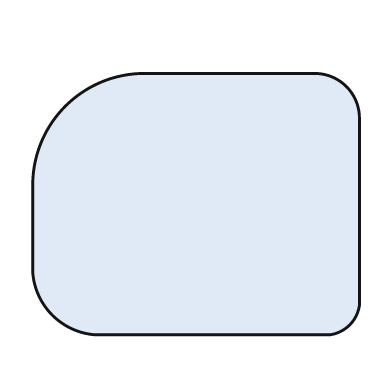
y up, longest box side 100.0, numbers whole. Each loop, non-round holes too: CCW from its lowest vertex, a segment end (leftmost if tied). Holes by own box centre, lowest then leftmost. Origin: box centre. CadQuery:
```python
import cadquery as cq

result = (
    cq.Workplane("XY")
    .moveTo(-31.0, -40.0)
    .lineTo(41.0, -40.0)
    .threePointArc((47.0, -37.0), (50.0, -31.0))
    .lineTo(50.0, 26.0)
    .threePointArc((46.0, 36.0), (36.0, 40.0))
    .lineTo(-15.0, 40.0)
    .threePointArc((-40.0, 30.0), (-50.0, 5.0))
    .lineTo(-50.0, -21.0)
    .threePointArc((-44.0, -34.0), (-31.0, -40.0))
    .close()
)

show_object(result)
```